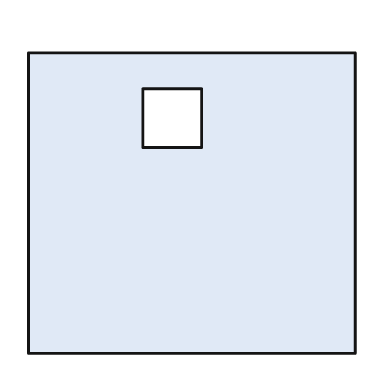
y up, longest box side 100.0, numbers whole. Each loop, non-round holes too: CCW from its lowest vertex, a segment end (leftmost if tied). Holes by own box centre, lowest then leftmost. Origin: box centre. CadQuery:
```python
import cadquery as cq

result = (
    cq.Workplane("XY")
    .moveTo(-50.0, -46.0)
    .lineTo(50.0, -46.0)
    .lineTo(50.0, 46.0)
    .lineTo(-50.0, 46.0)
    .close()
    .moveTo(-15.0, 17.0)
    .lineTo(3.0, 17.0)
    .lineTo(3.0, 35.0)
    .lineTo(-15.0, 35.0)
    .close()
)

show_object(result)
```